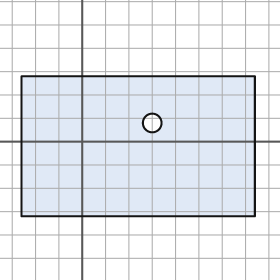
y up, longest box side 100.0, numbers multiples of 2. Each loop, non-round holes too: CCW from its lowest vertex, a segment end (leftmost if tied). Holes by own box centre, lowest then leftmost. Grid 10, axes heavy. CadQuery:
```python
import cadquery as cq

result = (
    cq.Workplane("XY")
    .moveTo(-26.0, -32.0)
    .lineTo(74.0, -32.0)
    .lineTo(74.0, 28.0)
    .lineTo(-26.0, 28.0)
    .close()
    .moveTo(30.0, 8.0)
    .circle(4.0)
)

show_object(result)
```